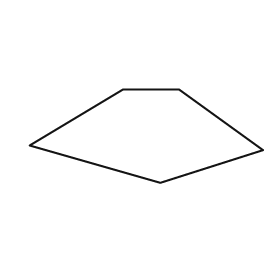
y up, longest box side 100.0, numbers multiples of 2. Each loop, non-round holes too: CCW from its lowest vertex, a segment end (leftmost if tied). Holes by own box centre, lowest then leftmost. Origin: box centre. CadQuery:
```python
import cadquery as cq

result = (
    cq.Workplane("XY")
    .moveTo(6.0, -20.0)
    .lineTo(50.0, -6.0)
    .lineTo(14.0, 20.0)
    .lineTo(-10.0, 20.0)
    .lineTo(-50.0, -4.0)
    .close()
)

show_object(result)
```